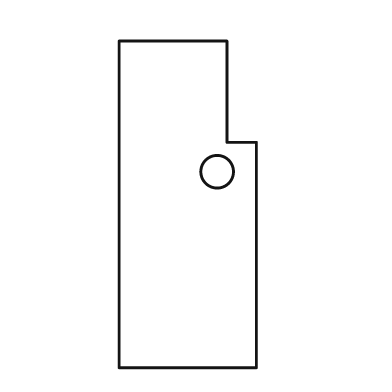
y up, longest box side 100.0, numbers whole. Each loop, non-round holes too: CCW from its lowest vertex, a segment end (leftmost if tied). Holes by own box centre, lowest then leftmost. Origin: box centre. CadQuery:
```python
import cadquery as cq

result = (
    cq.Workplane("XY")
    .moveTo(-21.0, -50.0)
    .lineTo(21.0, -50.0)
    .lineTo(21.0, 19.0)
    .lineTo(12.0, 19.0)
    .lineTo(12.0, 50.0)
    .lineTo(-21.0, 50.0)
    .close()
    .moveTo(9.0, 10.0)
    .circle(5.0)
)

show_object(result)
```